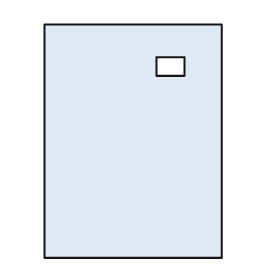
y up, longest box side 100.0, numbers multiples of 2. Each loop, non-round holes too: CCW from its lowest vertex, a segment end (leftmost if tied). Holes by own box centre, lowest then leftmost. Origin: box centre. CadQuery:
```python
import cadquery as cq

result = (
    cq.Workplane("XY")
    .moveTo(-38.0, -50.0)
    .lineTo(38.0, -50.0)
    .lineTo(38.0, 50.0)
    .lineTo(-38.0, 50.0)
    .close()
    .moveTo(10.0, 28.0)
    .lineTo(22.0, 28.0)
    .lineTo(22.0, 36.0)
    .lineTo(10.0, 36.0)
    .close()
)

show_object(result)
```